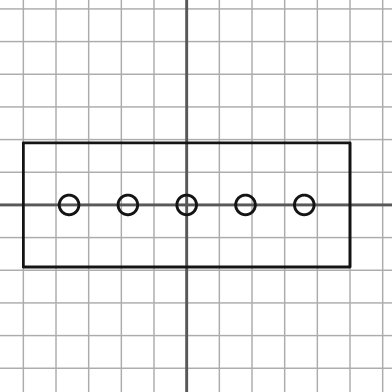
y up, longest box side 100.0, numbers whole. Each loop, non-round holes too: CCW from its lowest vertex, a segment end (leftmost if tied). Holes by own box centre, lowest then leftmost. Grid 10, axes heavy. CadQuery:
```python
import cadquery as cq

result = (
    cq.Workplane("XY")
    .moveTo(-50.0, -19.0)
    .lineTo(50.0, -19.0)
    .lineTo(50.0, 19.0)
    .lineTo(-50.0, 19.0)
    .close()
    .moveTo(-36.0, 0.0)
    .circle(3.0)
    .moveTo(-18.0, 0.0)
    .circle(3.0)
    .moveTo(0.0, 0.0)
    .circle(3.0)
    .moveTo(18.0, 0.0)
    .circle(3.0)
    .moveTo(36.0, 0.0)
    .circle(3.0)
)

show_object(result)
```